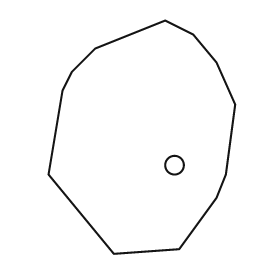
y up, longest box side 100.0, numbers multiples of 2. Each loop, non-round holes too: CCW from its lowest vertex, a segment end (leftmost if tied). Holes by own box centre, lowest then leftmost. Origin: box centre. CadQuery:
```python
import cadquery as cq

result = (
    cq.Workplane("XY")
    .moveTo(-12.0, -50.0)
    .lineTo(16.0, -48.0)
    .lineTo(32.0, -26.0)
    .lineTo(36.0, -16.0)
    .lineTo(40.0, 14.0)
    .lineTo(32.0, 32.0)
    .lineTo(22.0, 44.0)
    .lineTo(10.0, 50.0)
    .lineTo(-20.0, 38.0)
    .lineTo(-30.0, 28.0)
    .lineTo(-34.0, 20.0)
    .lineTo(-40.0, -16.0)
    .close()
    .moveTo(14.0, -12.0)
    .circle(4.0)
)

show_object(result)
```